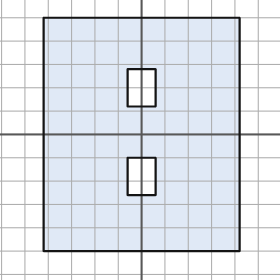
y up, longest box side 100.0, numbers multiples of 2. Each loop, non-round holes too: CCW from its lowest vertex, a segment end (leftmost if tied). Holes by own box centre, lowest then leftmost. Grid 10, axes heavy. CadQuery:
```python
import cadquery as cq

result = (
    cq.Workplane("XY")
    .moveTo(-42.0, -50.0)
    .lineTo(42.0, -50.0)
    .lineTo(42.0, 50.0)
    .lineTo(-42.0, 50.0)
    .close()
    .moveTo(-6.0, -26.0)
    .lineTo(6.0, -26.0)
    .lineTo(6.0, -10.0)
    .lineTo(-6.0, -10.0)
    .close()
    .moveTo(-6.0, 12.0)
    .lineTo(6.0, 12.0)
    .lineTo(6.0, 28.0)
    .lineTo(-6.0, 28.0)
    .close()
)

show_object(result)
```